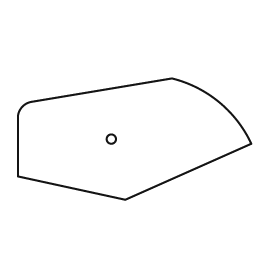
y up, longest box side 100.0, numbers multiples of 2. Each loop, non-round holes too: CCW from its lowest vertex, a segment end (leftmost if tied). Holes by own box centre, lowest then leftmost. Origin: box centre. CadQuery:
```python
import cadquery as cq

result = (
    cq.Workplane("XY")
    .moveTo(-4.0, -26.0)
    .lineTo(50.0, -2.0)
    .threePointArc((36.0, 16.0), (16.0, 26.0))
    .lineTo(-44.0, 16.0)
    .threePointArc((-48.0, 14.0), (-50.0, 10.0))
    .lineTo(-50.0, -16.0)
    .close()
    .moveTo(-10.0, 0.0)
    .circle(2.0)
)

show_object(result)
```